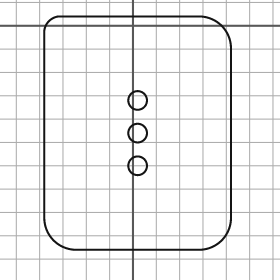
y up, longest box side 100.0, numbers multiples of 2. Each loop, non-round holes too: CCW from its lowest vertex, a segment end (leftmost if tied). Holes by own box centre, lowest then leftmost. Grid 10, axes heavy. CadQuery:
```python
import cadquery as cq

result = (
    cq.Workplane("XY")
    .moveTo(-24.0, -96.0)
    .lineTo(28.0, -96.0)
    .threePointArc((38.0, -92.0), (42.0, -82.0))
    .lineTo(42.0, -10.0)
    .threePointArc((38.0, 0.0), (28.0, 4.0))
    .lineTo(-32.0, 4.0)
    .threePointArc((-36.0, 2.0), (-38.0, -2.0))
    .lineTo(-38.0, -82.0)
    .threePointArc((-34.0, -92.0), (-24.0, -96.0))
    .close()
    .moveTo(2.0, -60.0)
    .circle(4.0)
    .moveTo(2.0, -46.0)
    .circle(4.0)
    .moveTo(2.0, -32.0)
    .circle(4.0)
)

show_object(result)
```